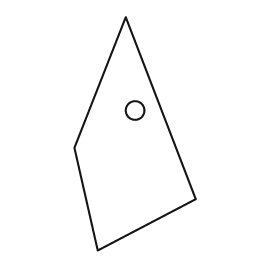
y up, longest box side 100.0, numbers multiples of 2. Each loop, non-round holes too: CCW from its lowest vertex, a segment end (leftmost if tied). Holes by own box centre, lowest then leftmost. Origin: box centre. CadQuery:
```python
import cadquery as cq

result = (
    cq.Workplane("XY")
    .moveTo(-16.0, -50.0)
    .lineTo(26.0, -28.0)
    .lineTo(-4.0, 50.0)
    .lineTo(-26.0, -6.0)
    .close()
    .moveTo(0.0, 10.0)
    .circle(4.0)
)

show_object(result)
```